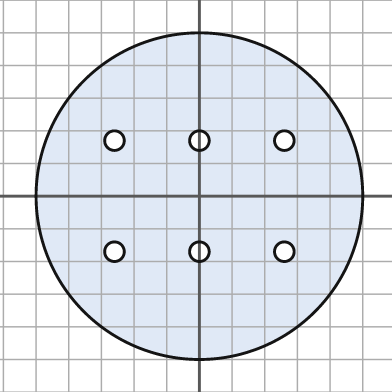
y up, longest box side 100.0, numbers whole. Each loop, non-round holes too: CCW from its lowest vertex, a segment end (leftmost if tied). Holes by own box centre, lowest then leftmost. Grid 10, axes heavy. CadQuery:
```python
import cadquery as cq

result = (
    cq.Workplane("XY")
    .moveTo(0.0, 0.0)
    .circle(50.0)
    .moveTo(-26.0, -17.0)
    .circle(3.0)
    .moveTo(0.0, -17.0)
    .circle(3.0)
    .moveTo(26.0, -17.0)
    .circle(3.0)
    .moveTo(-26.0, 17.0)
    .circle(3.0)
    .moveTo(0.0, 17.0)
    .circle(3.0)
    .moveTo(26.0, 17.0)
    .circle(3.0)
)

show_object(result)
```